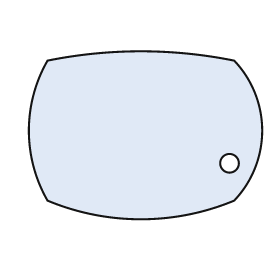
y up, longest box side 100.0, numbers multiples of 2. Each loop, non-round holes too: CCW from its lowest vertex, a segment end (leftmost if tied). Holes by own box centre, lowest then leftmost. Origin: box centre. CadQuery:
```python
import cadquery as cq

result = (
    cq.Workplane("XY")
    .moveTo(-42.0, -28.0)
    .threePointArc((-2.0, -36.0), (38.0, -28.0))
    .threePointArc((50.0, 2.0), (38.0, 32.0))
    .threePointArc((-2.0, 36.0), (-42.0, 32.0))
    .threePointArc((-50.0, 2.0), (-42.0, -28.0))
    .close()
    .moveTo(36.0, -12.0)
    .circle(4.0)
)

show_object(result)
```